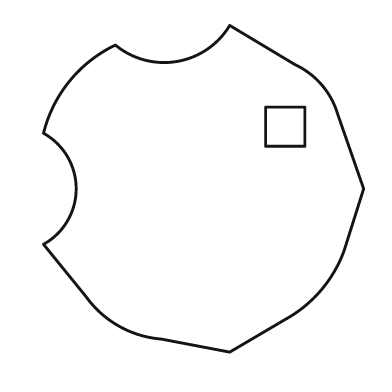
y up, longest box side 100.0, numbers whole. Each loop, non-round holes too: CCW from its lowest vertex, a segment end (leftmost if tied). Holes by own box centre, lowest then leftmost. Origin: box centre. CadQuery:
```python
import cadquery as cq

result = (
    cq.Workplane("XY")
    .moveTo(8.0, -50.0)
    .lineTo(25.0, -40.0)
    .threePointArc((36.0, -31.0), (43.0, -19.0))
    .lineTo(49.0, 0.0)
    .lineTo(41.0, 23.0)
    .threePointArc((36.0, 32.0), (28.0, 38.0))
    .lineTo(8.0, 50.0)
    .threePointArc((-8.0, 39.0), (-27.0, 44.0))
    .threePointArc((-41.0, 33.0), (-49.0, 17.0))
    .threePointArc((-39.0, 0.0), (-49.0, -17.0))
    .lineTo(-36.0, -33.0)
    .threePointArc((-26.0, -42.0), (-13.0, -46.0))
    .close()
    .moveTo(19.0, 13.0)
    .lineTo(31.0, 13.0)
    .lineTo(31.0, 25.0)
    .lineTo(19.0, 25.0)
    .close()
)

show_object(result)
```